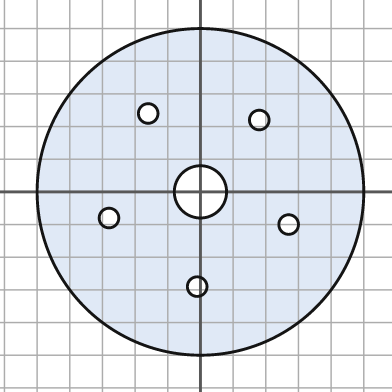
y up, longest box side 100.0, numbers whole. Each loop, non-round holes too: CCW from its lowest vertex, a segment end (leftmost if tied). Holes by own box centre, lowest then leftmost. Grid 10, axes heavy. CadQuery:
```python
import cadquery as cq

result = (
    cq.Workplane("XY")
    .moveTo(0.0, 0.0)
    .circle(50.0)
    .moveTo(-1.0, -29.0)
    .circle(3.0)
    .moveTo(27.0, -10.0)
    .circle(3.0)
    .moveTo(-28.0, -8.0)
    .circle(3.0)
    .moveTo(0.0, 0.0)
    .circle(8.0)
    .moveTo(18.0, 22.0)
    .circle(3.0)
    .moveTo(-16.0, 24.0)
    .circle(3.0)
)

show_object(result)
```